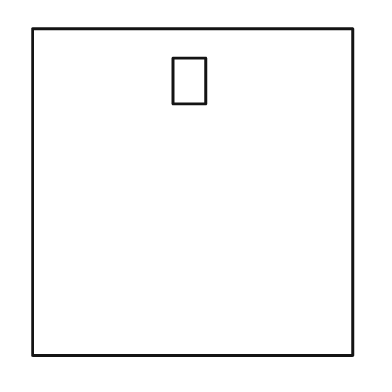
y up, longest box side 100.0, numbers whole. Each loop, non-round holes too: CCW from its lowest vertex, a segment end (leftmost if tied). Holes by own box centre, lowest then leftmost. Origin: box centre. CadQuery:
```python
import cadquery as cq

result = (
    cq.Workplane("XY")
    .moveTo(-49.0, -50.0)
    .lineTo(49.0, -50.0)
    .lineTo(49.0, 50.0)
    .lineTo(-49.0, 50.0)
    .close()
    .moveTo(-6.0, 27.0)
    .lineTo(4.0, 27.0)
    .lineTo(4.0, 41.0)
    .lineTo(-6.0, 41.0)
    .close()
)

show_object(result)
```